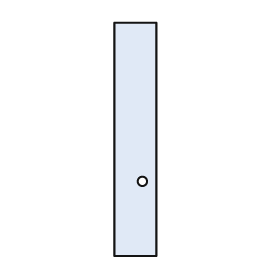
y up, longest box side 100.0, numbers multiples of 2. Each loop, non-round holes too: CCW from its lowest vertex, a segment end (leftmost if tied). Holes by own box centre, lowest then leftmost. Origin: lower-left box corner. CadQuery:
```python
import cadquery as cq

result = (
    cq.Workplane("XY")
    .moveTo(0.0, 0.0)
    .lineTo(18.0, 0.0)
    .lineTo(18.0, 100.0)
    .lineTo(0.0, 100.0)
    .close()
    .moveTo(12.0, 32.0)
    .circle(2.0)
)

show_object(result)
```